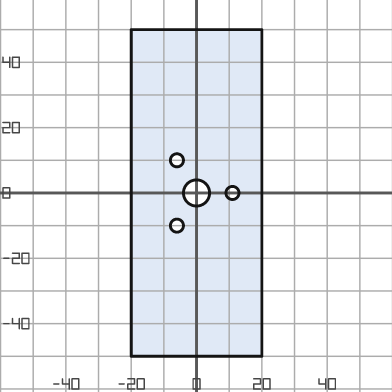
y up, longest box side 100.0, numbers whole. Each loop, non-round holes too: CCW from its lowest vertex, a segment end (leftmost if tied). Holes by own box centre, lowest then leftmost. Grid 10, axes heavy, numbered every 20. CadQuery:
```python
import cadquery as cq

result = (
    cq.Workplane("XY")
    .moveTo(-20.0, -50.0)
    .lineTo(20.0, -50.0)
    .lineTo(20.0, 50.0)
    .lineTo(-20.0, 50.0)
    .close()
    .moveTo(-6.0, -10.0)
    .circle(2.0)
    .moveTo(0.0, 0.0)
    .circle(4.0)
    .moveTo(11.0, 0.0)
    .circle(2.0)
    .moveTo(-6.0, 10.0)
    .circle(2.0)
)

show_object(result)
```